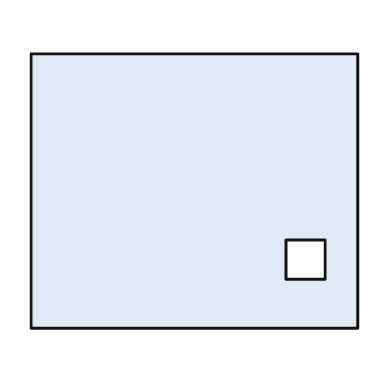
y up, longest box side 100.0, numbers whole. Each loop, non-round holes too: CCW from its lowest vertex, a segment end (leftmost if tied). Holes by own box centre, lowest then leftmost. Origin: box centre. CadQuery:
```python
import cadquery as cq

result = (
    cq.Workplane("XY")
    .moveTo(-50.0, -42.0)
    .lineTo(50.0, -42.0)
    .lineTo(50.0, 42.0)
    .lineTo(-50.0, 42.0)
    .close()
    .moveTo(28.0, -27.0)
    .lineTo(40.0, -27.0)
    .lineTo(40.0, -15.0)
    .lineTo(28.0, -15.0)
    .close()
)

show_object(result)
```